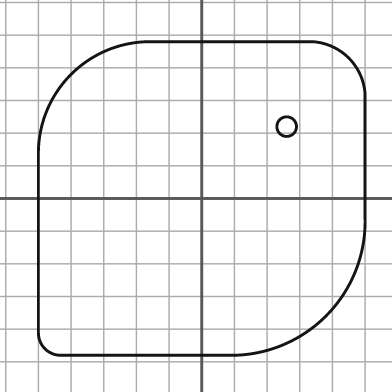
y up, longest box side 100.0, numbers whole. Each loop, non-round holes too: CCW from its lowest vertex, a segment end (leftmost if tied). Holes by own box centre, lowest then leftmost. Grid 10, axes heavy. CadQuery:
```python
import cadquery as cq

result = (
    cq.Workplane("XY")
    .moveTo(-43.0, -48.0)
    .lineTo(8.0, -48.0)
    .threePointArc((38.0, -36.0), (50.0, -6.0))
    .lineTo(50.0, 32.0)
    .threePointArc((45.0, 43.0), (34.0, 48.0))
    .lineTo(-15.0, 48.0)
    .threePointArc((-40.0, 38.0), (-50.0, 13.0))
    .lineTo(-50.0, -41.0)
    .threePointArc((-48.0, -46.0), (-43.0, -48.0))
    .close()
    .moveTo(26.0, 22.0)
    .circle(3.0)
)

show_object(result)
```